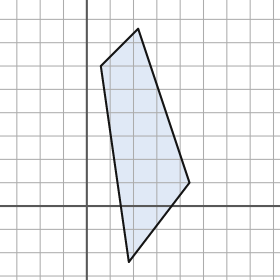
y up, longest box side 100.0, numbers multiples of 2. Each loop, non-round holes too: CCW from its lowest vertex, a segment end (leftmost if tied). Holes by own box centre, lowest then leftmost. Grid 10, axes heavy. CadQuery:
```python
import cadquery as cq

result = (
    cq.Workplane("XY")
    .moveTo(18.0, -24.0)
    .lineTo(44.0, 10.0)
    .lineTo(22.0, 76.0)
    .lineTo(6.0, 60.0)
    .close()
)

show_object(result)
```